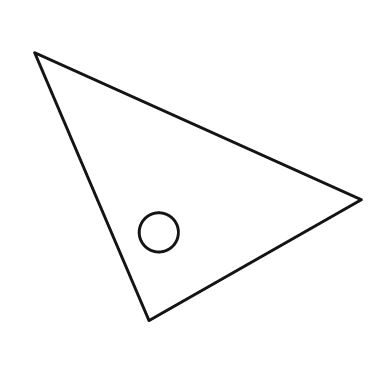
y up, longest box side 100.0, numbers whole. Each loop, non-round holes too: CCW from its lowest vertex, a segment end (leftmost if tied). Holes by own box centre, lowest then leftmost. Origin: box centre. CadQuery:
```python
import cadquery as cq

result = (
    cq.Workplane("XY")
    .moveTo(-15.0, -41.0)
    .lineTo(50.0, -4.0)
    .lineTo(-50.0, 41.0)
    .close()
    .moveTo(-12.0, -14.0)
    .circle(6.0)
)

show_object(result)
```